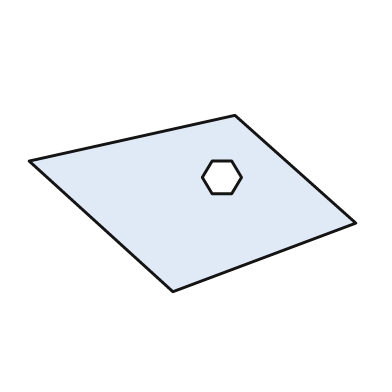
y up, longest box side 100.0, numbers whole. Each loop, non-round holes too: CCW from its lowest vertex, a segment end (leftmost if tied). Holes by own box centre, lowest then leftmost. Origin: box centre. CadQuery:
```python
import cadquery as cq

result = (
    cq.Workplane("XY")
    .moveTo(-6.0, -27.0)
    .lineTo(50.0, -6.0)
    .lineTo(13.0, 27.0)
    .lineTo(-50.0, 13.0)
    .close()
    .moveTo(6.0, 3.0)
    .lineTo(12.0, 3.0)
    .lineTo(15.0, 8.0)
    .lineTo(12.0, 13.0)
    .lineTo(6.0, 13.0)
    .lineTo(3.0, 8.0)
    .close()
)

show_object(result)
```